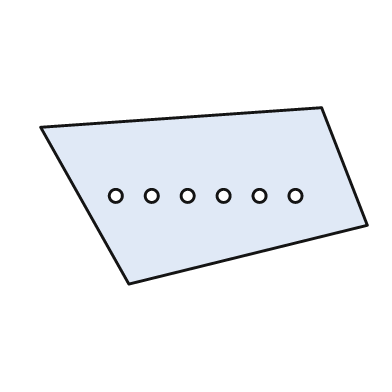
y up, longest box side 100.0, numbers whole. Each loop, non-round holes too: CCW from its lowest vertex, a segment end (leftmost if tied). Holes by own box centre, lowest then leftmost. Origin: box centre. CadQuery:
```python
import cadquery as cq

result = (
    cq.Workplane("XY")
    .moveTo(-23.0, -27.0)
    .lineTo(50.0, -9.0)
    .lineTo(36.0, 27.0)
    .lineTo(-50.0, 21.0)
    .close()
    .moveTo(-27.0, 0.0)
    .circle(2.0)
    .moveTo(-16.0, 0.0)
    .circle(2.0)
    .moveTo(-5.0, 0.0)
    .circle(2.0)
    .moveTo(6.0, 0.0)
    .circle(2.0)
    .moveTo(17.0, 0.0)
    .circle(2.0)
    .moveTo(28.0, 0.0)
    .circle(2.0)
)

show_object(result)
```